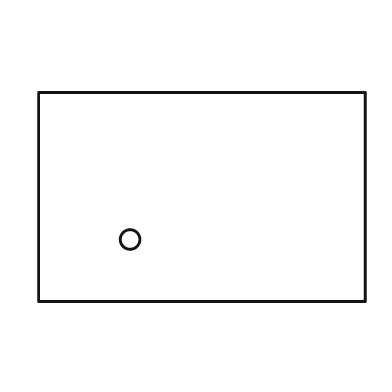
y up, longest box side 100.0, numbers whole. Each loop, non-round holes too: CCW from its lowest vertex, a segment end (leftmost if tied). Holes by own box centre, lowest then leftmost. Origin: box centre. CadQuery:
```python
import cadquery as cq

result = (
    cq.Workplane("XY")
    .moveTo(-50.0, -32.0)
    .lineTo(50.0, -32.0)
    .lineTo(50.0, 32.0)
    .lineTo(-50.0, 32.0)
    .close()
    .moveTo(-22.0, -13.0)
    .circle(3.0)
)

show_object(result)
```